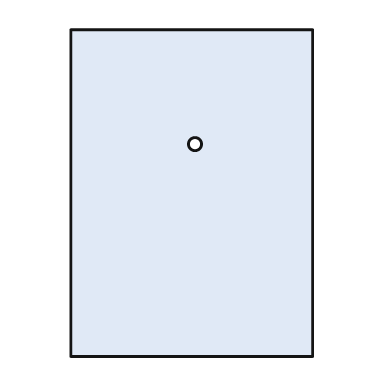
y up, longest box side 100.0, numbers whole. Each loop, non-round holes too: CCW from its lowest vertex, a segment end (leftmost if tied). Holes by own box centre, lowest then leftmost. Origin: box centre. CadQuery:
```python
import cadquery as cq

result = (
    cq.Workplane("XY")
    .moveTo(-37.0, -50.0)
    .lineTo(37.0, -50.0)
    .lineTo(37.0, 50.0)
    .lineTo(-37.0, 50.0)
    .close()
    .moveTo(1.0, 15.0)
    .circle(2.0)
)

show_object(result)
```